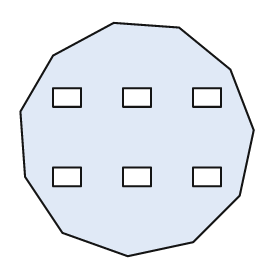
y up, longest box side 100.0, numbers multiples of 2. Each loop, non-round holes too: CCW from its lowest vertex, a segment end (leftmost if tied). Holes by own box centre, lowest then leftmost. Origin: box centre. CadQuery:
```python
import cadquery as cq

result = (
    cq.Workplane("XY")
    .moveTo(-4.0, -50.0)
    .lineTo(24.0, -44.0)
    .lineTo(44.0, -24.0)
    .lineTo(50.0, 4.0)
    .lineTo(40.0, 30.0)
    .lineTo(18.0, 48.0)
    .lineTo(-10.0, 50.0)
    .lineTo(-36.0, 36.0)
    .lineTo(-50.0, 12.0)
    .lineTo(-48.0, -16.0)
    .lineTo(-32.0, -40.0)
    .close()
    .moveTo(-36.0, -20.0)
    .lineTo(-24.0, -20.0)
    .lineTo(-24.0, -12.0)
    .lineTo(-36.0, -12.0)
    .close()
    .moveTo(-6.0, -20.0)
    .lineTo(6.0, -20.0)
    .lineTo(6.0, -12.0)
    .lineTo(-6.0, -12.0)
    .close()
    .moveTo(24.0, -20.0)
    .lineTo(36.0, -20.0)
    .lineTo(36.0, -12.0)
    .lineTo(24.0, -12.0)
    .close()
    .moveTo(-36.0, 14.0)
    .lineTo(-24.0, 14.0)
    .lineTo(-24.0, 22.0)
    .lineTo(-36.0, 22.0)
    .close()
    .moveTo(-6.0, 14.0)
    .lineTo(6.0, 14.0)
    .lineTo(6.0, 22.0)
    .lineTo(-6.0, 22.0)
    .close()
    .moveTo(24.0, 14.0)
    .lineTo(36.0, 14.0)
    .lineTo(36.0, 22.0)
    .lineTo(24.0, 22.0)
    .close()
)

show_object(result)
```